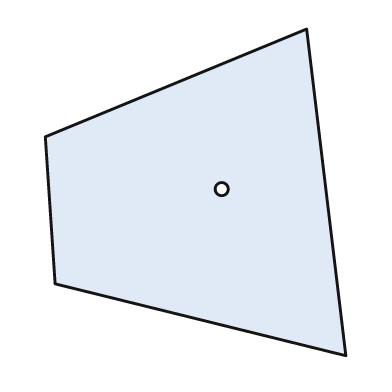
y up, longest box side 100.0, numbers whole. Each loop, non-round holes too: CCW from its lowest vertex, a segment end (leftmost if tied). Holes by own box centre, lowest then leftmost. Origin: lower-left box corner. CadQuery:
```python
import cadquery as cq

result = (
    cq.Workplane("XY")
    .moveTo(92.0, 0.0)
    .lineTo(80.0, 100.0)
    .lineTo(0.0, 67.0)
    .lineTo(3.0, 22.0)
    .close()
    .moveTo(54.0, 51.0)
    .circle(2.0)
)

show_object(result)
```